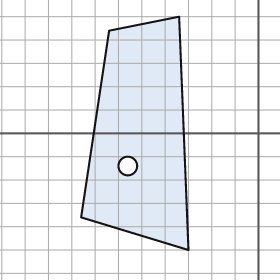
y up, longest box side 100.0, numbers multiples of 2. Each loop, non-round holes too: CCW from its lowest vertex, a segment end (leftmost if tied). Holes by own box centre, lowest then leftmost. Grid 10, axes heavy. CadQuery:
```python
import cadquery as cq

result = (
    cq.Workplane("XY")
    .moveTo(-30.0, -50.0)
    .lineTo(-34.0, 50.0)
    .lineTo(-64.0, 44.0)
    .lineTo(-76.0, -36.0)
    .close()
    .moveTo(-56.0, -14.0)
    .circle(4.0)
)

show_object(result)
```